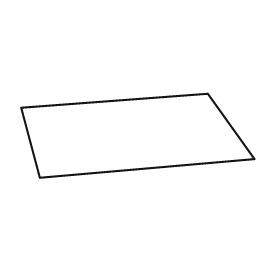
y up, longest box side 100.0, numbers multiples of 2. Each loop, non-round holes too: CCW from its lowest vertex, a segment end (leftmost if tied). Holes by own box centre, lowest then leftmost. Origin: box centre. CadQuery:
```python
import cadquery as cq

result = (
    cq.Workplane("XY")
    .moveTo(-42.0, -18.0)
    .lineTo(50.0, -10.0)
    .lineTo(30.0, 18.0)
    .lineTo(-50.0, 12.0)
    .close()
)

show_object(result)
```